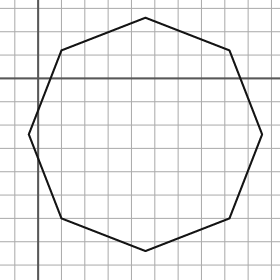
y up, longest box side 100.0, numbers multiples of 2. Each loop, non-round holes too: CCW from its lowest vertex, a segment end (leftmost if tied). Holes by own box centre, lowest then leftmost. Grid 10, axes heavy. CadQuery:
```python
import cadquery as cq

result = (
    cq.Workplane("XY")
    .moveTo(46.0, -74.0)
    .lineTo(82.0, -60.0)
    .lineTo(96.0, -24.0)
    .lineTo(82.0, 12.0)
    .lineTo(46.0, 26.0)
    .lineTo(10.0, 12.0)
    .lineTo(-4.0, -24.0)
    .lineTo(10.0, -60.0)
    .close()
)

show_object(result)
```